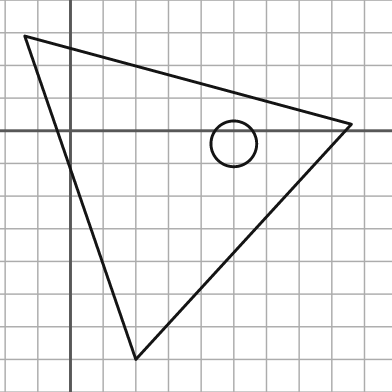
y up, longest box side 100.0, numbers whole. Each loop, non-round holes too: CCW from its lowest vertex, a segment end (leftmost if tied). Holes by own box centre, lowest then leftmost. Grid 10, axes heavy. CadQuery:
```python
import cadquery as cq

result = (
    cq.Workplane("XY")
    .moveTo(20.0, -70.0)
    .lineTo(86.0, 2.0)
    .lineTo(-14.0, 29.0)
    .close()
    .moveTo(50.0, -4.0)
    .circle(7.0)
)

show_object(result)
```